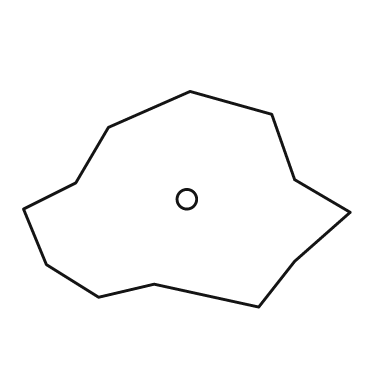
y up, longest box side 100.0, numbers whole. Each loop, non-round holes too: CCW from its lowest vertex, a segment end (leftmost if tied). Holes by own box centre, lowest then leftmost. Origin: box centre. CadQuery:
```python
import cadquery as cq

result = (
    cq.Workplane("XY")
    .moveTo(22.0, -33.0)
    .lineTo(33.0, -19.0)
    .lineTo(50.0, -4.0)
    .lineTo(33.0, 6.0)
    .lineTo(26.0, 26.0)
    .lineTo(1.0, 33.0)
    .lineTo(-24.0, 22.0)
    .lineTo(-34.0, 5.0)
    .lineTo(-50.0, -3.0)
    .lineTo(-43.0, -20.0)
    .lineTo(-27.0, -30.0)
    .lineTo(-10.0, -26.0)
    .close()
    .moveTo(0.0, 0.0)
    .circle(3.0)
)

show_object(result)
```